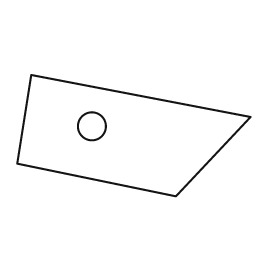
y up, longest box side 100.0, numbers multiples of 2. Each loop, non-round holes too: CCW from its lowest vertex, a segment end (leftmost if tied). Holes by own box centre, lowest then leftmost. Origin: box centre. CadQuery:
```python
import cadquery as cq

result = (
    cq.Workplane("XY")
    .moveTo(18.0, -26.0)
    .lineTo(50.0, 8.0)
    .lineTo(-44.0, 26.0)
    .lineTo(-50.0, -12.0)
    .close()
    .moveTo(-18.0, 4.0)
    .circle(6.0)
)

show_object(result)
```